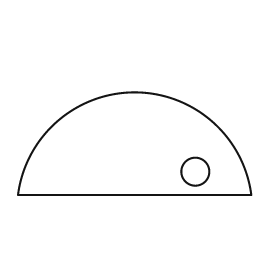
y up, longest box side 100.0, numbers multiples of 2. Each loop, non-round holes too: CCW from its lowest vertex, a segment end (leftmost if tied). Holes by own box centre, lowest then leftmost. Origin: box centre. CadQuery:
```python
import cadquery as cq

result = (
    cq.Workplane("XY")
    .moveTo(-50.0, -22.0)
    .lineTo(50.0, -22.0)
    .threePointArc((0.0, 22.0), (-50.0, -22.0))
    .close()
    .moveTo(26.0, -12.0)
    .circle(6.0)
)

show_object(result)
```